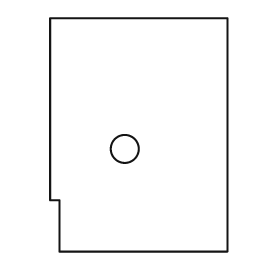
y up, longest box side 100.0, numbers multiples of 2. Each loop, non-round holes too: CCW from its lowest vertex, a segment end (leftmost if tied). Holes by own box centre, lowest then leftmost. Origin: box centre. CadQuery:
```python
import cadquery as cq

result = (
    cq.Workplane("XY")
    .moveTo(-34.0, -50.0)
    .lineTo(38.0, -50.0)
    .lineTo(38.0, 50.0)
    .lineTo(-38.0, 50.0)
    .lineTo(-38.0, -28.0)
    .lineTo(-34.0, -28.0)
    .close()
    .moveTo(-6.0, -6.0)
    .circle(6.0)
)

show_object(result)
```